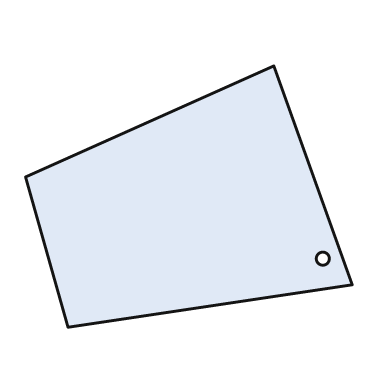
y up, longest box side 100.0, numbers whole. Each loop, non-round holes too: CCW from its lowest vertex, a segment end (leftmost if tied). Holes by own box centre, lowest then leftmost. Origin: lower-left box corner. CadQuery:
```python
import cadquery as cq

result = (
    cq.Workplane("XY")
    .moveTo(13.0, 0.0)
    .lineTo(100.0, 13.0)
    .lineTo(76.0, 80.0)
    .lineTo(0.0, 46.0)
    .close()
    .moveTo(91.0, 21.0)
    .circle(2.0)
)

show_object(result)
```